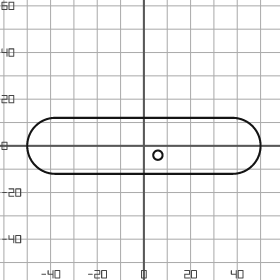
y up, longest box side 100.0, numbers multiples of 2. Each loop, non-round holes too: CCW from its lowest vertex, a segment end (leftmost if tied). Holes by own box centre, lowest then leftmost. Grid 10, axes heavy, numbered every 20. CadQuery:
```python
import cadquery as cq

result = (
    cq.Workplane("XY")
    .moveTo(-38.0, -12.0)
    .lineTo(38.0, -12.0)
    .threePointArc((50.0, 0.0), (38.0, 12.0))
    .lineTo(-38.0, 12.0)
    .threePointArc((-50.0, 0.0), (-38.0, -12.0))
    .close()
    .moveTo(6.0, -4.0)
    .circle(2.0)
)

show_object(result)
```